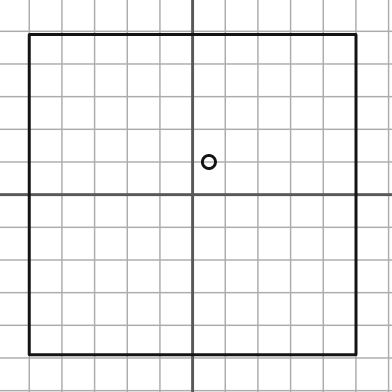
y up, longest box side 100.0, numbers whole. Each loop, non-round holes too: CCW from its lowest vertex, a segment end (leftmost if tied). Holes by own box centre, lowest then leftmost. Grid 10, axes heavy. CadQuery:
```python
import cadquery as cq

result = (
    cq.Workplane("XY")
    .moveTo(-50.0, -49.0)
    .lineTo(50.0, -49.0)
    .lineTo(50.0, 49.0)
    .lineTo(-50.0, 49.0)
    .close()
    .moveTo(5.0, 10.0)
    .circle(2.0)
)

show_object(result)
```